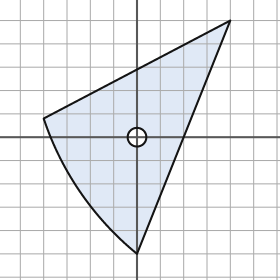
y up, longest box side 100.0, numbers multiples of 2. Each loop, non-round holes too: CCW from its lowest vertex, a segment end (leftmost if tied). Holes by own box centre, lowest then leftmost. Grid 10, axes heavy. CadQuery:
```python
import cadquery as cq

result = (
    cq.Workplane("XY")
    .moveTo(0.0, -50.0)
    .lineTo(40.0, 50.0)
    .lineTo(-40.0, 8.0)
    .threePointArc((-24.0, -24.0), (0.0, -50.0))
    .close()
    .moveTo(0.0, 0.0)
    .circle(4.0)
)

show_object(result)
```